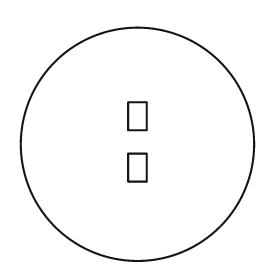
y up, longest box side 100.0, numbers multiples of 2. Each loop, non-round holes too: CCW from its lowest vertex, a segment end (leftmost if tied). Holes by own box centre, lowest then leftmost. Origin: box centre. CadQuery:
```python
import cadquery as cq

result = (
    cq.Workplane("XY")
    .moveTo(0.0, 0.0)
    .circle(50.0)
    .moveTo(-4.0, -16.0)
    .lineTo(4.0, -16.0)
    .lineTo(4.0, -4.0)
    .lineTo(-4.0, -4.0)
    .close()
    .moveTo(-4.0, 6.0)
    .lineTo(4.0, 6.0)
    .lineTo(4.0, 18.0)
    .lineTo(-4.0, 18.0)
    .close()
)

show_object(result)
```